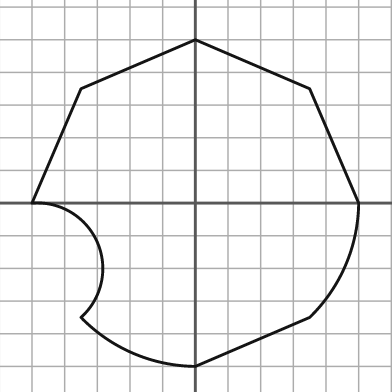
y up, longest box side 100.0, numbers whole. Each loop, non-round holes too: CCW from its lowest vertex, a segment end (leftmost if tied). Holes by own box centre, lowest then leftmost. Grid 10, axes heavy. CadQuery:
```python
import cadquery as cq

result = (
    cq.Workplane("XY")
    .moveTo(0.0, -50.0)
    .lineTo(35.0, -35.0)
    .threePointArc((46.0, -19.0), (50.0, 0.0))
    .lineTo(35.0, 35.0)
    .lineTo(0.0, 50.0)
    .lineTo(-35.0, 35.0)
    .lineTo(-50.0, 0.0)
    .threePointArc((-30.0, -12.0), (-35.0, -35.0))
    .threePointArc((-19.0, -46.0), (0.0, -50.0))
    .close()
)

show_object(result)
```